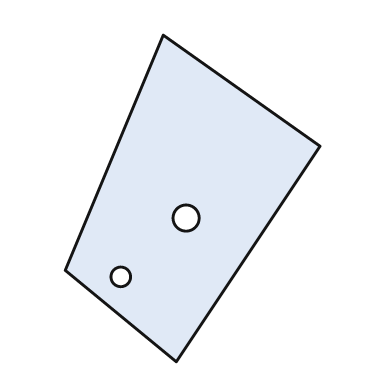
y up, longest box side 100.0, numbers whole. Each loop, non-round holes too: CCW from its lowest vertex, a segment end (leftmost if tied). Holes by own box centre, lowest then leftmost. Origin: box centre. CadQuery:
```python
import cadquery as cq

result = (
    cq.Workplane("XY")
    .moveTo(-5.0, -50.0)
    .lineTo(39.0, 16.0)
    .lineTo(-9.0, 50.0)
    .lineTo(-39.0, -22.0)
    .close()
    .moveTo(-22.0, -24.0)
    .circle(3.0)
    .moveTo(-2.0, -6.0)
    .circle(4.0)
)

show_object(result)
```